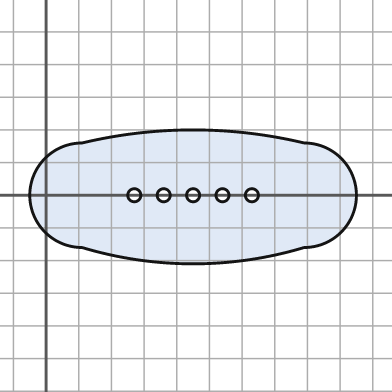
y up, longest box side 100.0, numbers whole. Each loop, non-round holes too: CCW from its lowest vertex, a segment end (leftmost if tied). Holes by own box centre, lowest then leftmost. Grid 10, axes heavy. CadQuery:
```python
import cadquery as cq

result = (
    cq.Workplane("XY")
    .moveTo(11.0, -16.0)
    .threePointArc((45.0, -21.0), (79.0, -16.0))
    .threePointArc((95.0, 0.0), (79.0, 16.0))
    .threePointArc((45.0, 20.0), (11.0, 16.0))
    .threePointArc((-5.0, 0.0), (11.0, -16.0))
    .close()
    .moveTo(27.0, 0.0)
    .circle(2.0)
    .moveTo(36.0, 0.0)
    .circle(2.0)
    .moveTo(45.0, 0.0)
    .circle(2.0)
    .moveTo(54.0, 0.0)
    .circle(2.0)
    .moveTo(63.0, 0.0)
    .circle(2.0)
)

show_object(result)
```